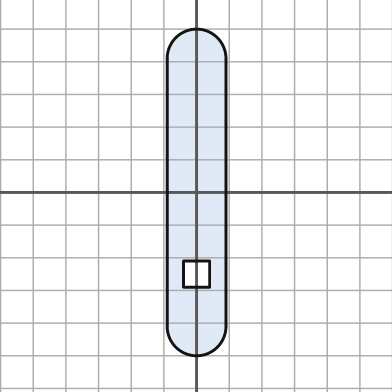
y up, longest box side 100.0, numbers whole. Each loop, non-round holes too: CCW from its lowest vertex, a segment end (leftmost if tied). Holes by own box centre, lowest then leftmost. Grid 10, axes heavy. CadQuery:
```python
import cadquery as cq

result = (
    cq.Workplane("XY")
    .moveTo(-9.0, -41.0)
    .threePointArc((0.0, -50.0), (9.0, -41.0))
    .lineTo(9.0, 41.0)
    .threePointArc((0.0, 50.0), (-9.0, 41.0))
    .close()
    .moveTo(-4.0, -29.0)
    .lineTo(4.0, -29.0)
    .lineTo(4.0, -21.0)
    .lineTo(-4.0, -21.0)
    .close()
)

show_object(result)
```